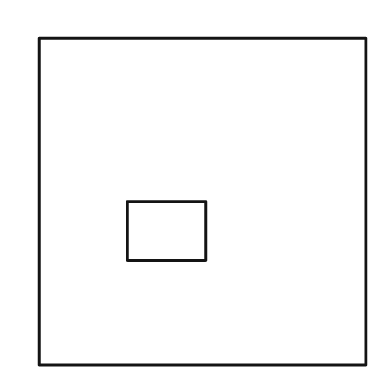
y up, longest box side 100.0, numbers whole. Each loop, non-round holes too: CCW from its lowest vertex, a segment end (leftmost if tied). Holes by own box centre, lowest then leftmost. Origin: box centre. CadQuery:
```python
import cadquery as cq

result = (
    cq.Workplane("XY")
    .moveTo(-50.0, -50.0)
    .lineTo(50.0, -50.0)
    .lineTo(50.0, 50.0)
    .lineTo(-50.0, 50.0)
    .close()
    .moveTo(-23.0, -18.0)
    .lineTo(1.0, -18.0)
    .lineTo(1.0, 0.0)
    .lineTo(-23.0, 0.0)
    .close()
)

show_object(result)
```